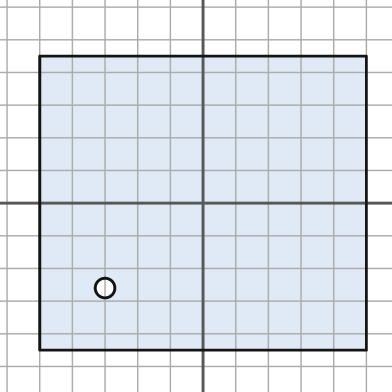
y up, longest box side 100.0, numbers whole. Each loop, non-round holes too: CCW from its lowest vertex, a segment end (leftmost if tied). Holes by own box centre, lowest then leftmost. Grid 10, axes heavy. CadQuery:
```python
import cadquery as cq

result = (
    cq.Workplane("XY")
    .moveTo(-50.0, -45.0)
    .lineTo(50.0, -45.0)
    .lineTo(50.0, 45.0)
    .lineTo(-50.0, 45.0)
    .close()
    .moveTo(-30.0, -26.0)
    .circle(3.0)
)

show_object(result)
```